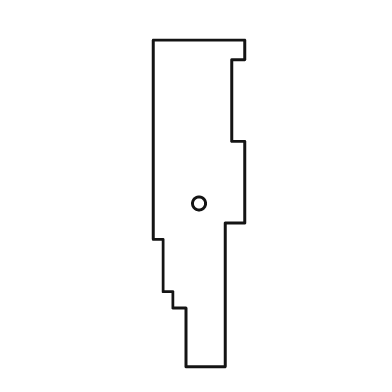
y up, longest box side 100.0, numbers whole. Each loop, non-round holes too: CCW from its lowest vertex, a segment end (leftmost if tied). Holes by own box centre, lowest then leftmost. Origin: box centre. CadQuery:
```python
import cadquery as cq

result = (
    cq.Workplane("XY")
    .moveTo(-4.0, -50.0)
    .lineTo(8.0, -50.0)
    .lineTo(8.0, -6.0)
    .lineTo(14.0, -6.0)
    .lineTo(14.0, 19.0)
    .lineTo(10.0, 19.0)
    .lineTo(10.0, 44.0)
    .lineTo(14.0, 44.0)
    .lineTo(14.0, 50.0)
    .lineTo(-14.0, 50.0)
    .lineTo(-14.0, -11.0)
    .lineTo(-11.0, -11.0)
    .lineTo(-11.0, -27.0)
    .lineTo(-8.0, -27.0)
    .lineTo(-8.0, -32.0)
    .lineTo(-4.0, -32.0)
    .close()
    .moveTo(0.0, 0.0)
    .circle(2.0)
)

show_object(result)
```